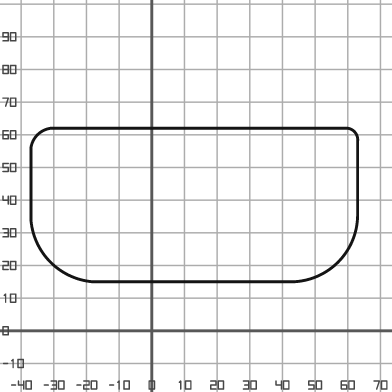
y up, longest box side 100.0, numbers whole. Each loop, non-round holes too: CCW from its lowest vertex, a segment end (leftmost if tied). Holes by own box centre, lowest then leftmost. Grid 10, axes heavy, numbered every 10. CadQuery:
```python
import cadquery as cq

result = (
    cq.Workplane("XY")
    .moveTo(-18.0, 15.0)
    .lineTo(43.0, 15.0)
    .threePointArc((57.0, 21.0), (63.0, 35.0))
    .lineTo(63.0, 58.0)
    .threePointArc((62.0, 61.0), (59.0, 62.0))
    .lineTo(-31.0, 62.0)
    .threePointArc((-35.0, 60.0), (-37.0, 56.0))
    .lineTo(-37.0, 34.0)
    .threePointArc((-31.0, 21.0), (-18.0, 15.0))
    .close()
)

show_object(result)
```